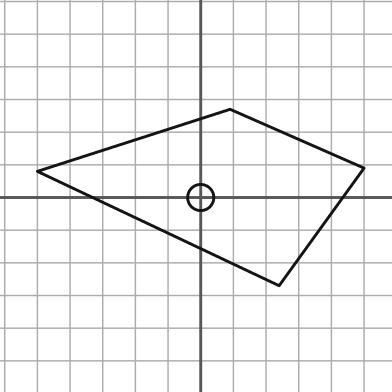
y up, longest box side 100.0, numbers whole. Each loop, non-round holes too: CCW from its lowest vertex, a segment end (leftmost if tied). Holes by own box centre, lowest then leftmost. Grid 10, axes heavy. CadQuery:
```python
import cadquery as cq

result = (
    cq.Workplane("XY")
    .moveTo(24.0, -27.0)
    .lineTo(50.0, 9.0)
    .lineTo(9.0, 27.0)
    .lineTo(-50.0, 8.0)
    .close()
    .moveTo(0.0, 0.0)
    .circle(4.0)
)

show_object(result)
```